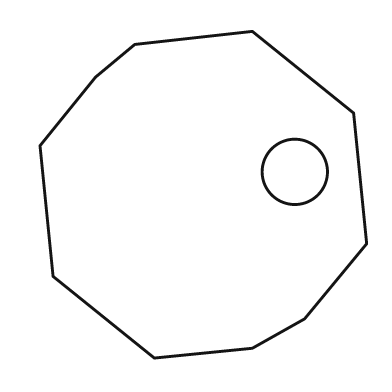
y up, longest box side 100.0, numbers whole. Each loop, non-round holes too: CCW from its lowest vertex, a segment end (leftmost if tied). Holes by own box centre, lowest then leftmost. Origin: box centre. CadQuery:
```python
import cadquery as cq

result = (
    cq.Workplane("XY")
    .moveTo(-15.0, -50.0)
    .lineTo(15.0, -47.0)
    .lineTo(31.0, -38.0)
    .lineTo(50.0, -15.0)
    .lineTo(46.0, 25.0)
    .lineTo(15.0, 50.0)
    .lineTo(-21.0, 46.0)
    .lineTo(-33.0, 36.0)
    .lineTo(-50.0, 15.0)
    .lineTo(-46.0, -25.0)
    .close()
    .moveTo(28.0, 7.0)
    .circle(10.0)
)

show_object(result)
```